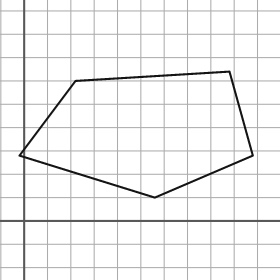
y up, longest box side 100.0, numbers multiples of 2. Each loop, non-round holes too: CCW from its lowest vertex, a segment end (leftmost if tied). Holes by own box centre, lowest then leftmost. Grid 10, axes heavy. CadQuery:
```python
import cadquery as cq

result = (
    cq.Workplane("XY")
    .moveTo(56.0, 10.0)
    .lineTo(98.0, 28.0)
    .lineTo(88.0, 64.0)
    .lineTo(22.0, 60.0)
    .lineTo(-2.0, 28.0)
    .close()
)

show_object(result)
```